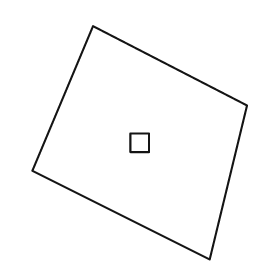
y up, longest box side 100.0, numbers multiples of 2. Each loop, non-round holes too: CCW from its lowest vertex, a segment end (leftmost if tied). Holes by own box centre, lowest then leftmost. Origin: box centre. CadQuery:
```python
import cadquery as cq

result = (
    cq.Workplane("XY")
    .moveTo(30.0, -50.0)
    .lineTo(46.0, 16.0)
    .lineTo(-20.0, 50.0)
    .lineTo(-46.0, -12.0)
    .close()
    .moveTo(-4.0, -4.0)
    .lineTo(4.0, -4.0)
    .lineTo(4.0, 4.0)
    .lineTo(-4.0, 4.0)
    .close()
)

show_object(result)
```